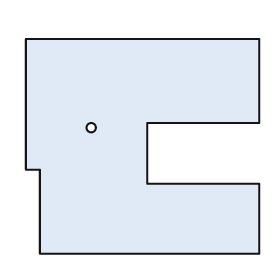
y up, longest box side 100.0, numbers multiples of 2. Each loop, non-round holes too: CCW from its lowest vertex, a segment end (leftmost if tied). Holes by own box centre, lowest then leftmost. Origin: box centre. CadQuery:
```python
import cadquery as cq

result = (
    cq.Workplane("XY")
    .moveTo(-44.0, -46.0)
    .lineTo(50.0, -46.0)
    .lineTo(50.0, -16.0)
    .lineTo(2.0, -16.0)
    .lineTo(2.0, 10.0)
    .lineTo(50.0, 10.0)
    .lineTo(50.0, 46.0)
    .lineTo(-50.0, 46.0)
    .lineTo(-50.0, -10.0)
    .lineTo(-44.0, -10.0)
    .close()
    .moveTo(-22.0, 8.0)
    .circle(2.0)
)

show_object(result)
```